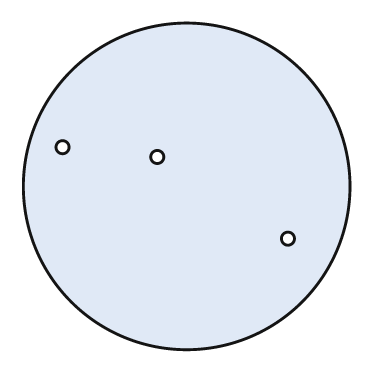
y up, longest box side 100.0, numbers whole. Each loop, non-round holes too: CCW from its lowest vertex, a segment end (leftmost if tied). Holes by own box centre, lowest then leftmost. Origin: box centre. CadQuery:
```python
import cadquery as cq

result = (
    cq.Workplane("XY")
    .moveTo(0.0, 0.0)
    .circle(50.0)
    .moveTo(31.0, -16.0)
    .circle(2.0)
    .moveTo(-9.0, 9.0)
    .circle(2.0)
    .moveTo(-38.0, 12.0)
    .circle(2.0)
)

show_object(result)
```